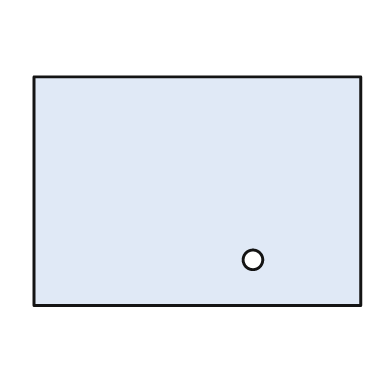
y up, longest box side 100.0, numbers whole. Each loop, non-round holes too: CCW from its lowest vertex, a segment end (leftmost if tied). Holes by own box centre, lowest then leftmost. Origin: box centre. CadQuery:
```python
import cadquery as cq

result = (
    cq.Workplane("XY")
    .moveTo(-50.0, -35.0)
    .lineTo(50.0, -35.0)
    .lineTo(50.0, 35.0)
    .lineTo(-50.0, 35.0)
    .close()
    .moveTo(17.0, -21.0)
    .circle(3.0)
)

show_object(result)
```